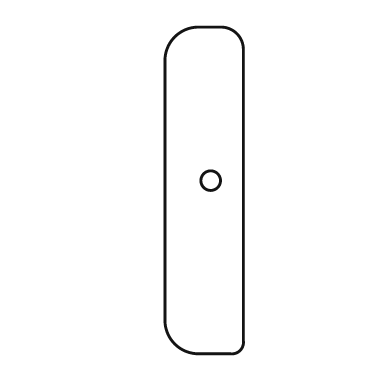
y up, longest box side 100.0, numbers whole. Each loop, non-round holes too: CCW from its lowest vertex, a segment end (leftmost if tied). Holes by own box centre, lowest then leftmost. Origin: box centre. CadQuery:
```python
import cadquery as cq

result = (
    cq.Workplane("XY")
    .moveTo(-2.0, -50.0)
    .lineTo(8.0, -50.0)
    .threePointArc((11.0, -49.0), (12.0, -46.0))
    .lineTo(12.0, 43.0)
    .threePointArc((10.0, 48.0), (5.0, 50.0))
    .lineTo(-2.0, 50.0)
    .threePointArc((-9.0, 47.0), (-12.0, 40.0))
    .lineTo(-12.0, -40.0)
    .threePointArc((-9.0, -47.0), (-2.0, -50.0))
    .close()
    .moveTo(2.0, 3.0)
    .circle(3.0)
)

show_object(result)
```